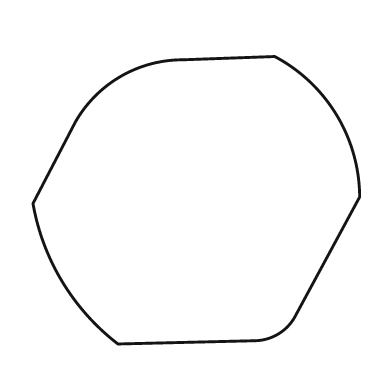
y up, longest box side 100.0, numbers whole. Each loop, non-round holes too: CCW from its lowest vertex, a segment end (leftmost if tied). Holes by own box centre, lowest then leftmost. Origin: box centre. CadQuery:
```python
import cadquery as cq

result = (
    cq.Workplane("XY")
    .moveTo(-24.0, -44.0)
    .lineTo(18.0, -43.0)
    .threePointArc((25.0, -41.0), (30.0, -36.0))
    .lineTo(50.0, 1.0)
    .threePointArc((43.0, 26.0), (24.0, 44.0))
    .lineTo(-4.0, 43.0)
    .threePointArc((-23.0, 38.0), (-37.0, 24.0))
    .lineTo(-50.0, -1.0)
    .threePointArc((-41.0, -25.0), (-24.0, -44.0))
    .close()
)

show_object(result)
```